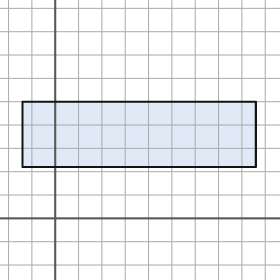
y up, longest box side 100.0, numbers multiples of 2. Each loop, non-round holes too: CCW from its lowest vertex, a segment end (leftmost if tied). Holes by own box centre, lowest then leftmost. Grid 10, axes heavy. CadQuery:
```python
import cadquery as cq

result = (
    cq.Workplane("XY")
    .moveTo(-14.0, 22.0)
    .lineTo(86.0, 22.0)
    .lineTo(86.0, 50.0)
    .lineTo(-14.0, 50.0)
    .close()
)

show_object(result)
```